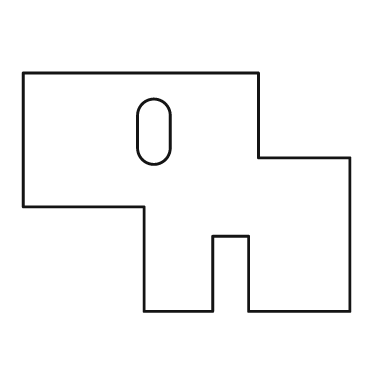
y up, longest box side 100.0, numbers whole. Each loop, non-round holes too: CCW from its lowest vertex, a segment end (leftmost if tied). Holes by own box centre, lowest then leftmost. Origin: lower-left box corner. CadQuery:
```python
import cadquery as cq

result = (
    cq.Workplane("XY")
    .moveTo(37.0, 0.0)
    .lineTo(58.0, 0.0)
    .lineTo(58.0, 23.0)
    .lineTo(69.0, 23.0)
    .lineTo(69.0, 0.0)
    .lineTo(100.0, 0.0)
    .lineTo(100.0, 47.0)
    .lineTo(72.0, 47.0)
    .lineTo(72.0, 73.0)
    .lineTo(0.0, 73.0)
    .lineTo(0.0, 32.0)
    .lineTo(37.0, 32.0)
    .close()
    .moveTo(35.0, 50.0)
    .threePointArc((40.0, 45.0), (45.0, 50.0))
    .lineTo(45.0, 60.0)
    .threePointArc((40.0, 65.0), (35.0, 60.0))
    .close()
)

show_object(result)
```